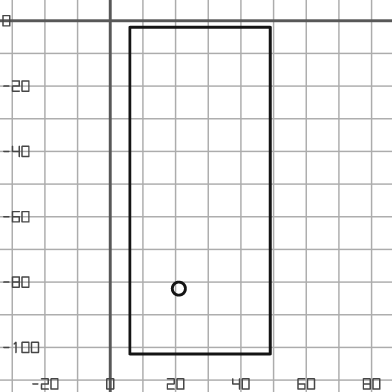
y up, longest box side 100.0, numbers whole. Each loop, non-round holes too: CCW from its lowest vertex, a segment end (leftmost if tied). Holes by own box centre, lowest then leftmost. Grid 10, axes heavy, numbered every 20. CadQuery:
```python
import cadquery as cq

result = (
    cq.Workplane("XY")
    .moveTo(6.0, -102.0)
    .lineTo(49.0, -102.0)
    .lineTo(49.0, -2.0)
    .lineTo(6.0, -2.0)
    .close()
    .moveTo(21.0, -82.0)
    .circle(2.0)
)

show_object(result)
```